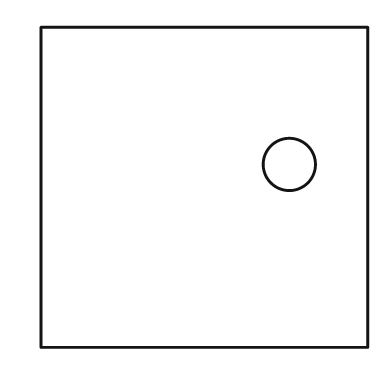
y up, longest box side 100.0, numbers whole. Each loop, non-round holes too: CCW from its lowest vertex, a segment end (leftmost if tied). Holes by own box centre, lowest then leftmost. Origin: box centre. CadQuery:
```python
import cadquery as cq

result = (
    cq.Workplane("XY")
    .moveTo(-50.0, -49.0)
    .lineTo(50.0, -49.0)
    .lineTo(50.0, 49.0)
    .lineTo(-50.0, 49.0)
    .close()
    .moveTo(26.0, 7.0)
    .circle(8.0)
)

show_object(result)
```